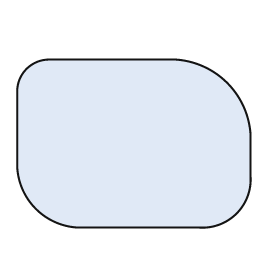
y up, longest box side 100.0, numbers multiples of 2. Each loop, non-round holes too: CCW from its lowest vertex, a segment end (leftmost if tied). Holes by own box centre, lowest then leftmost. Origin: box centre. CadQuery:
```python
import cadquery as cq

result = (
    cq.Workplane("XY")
    .moveTo(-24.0, -36.0)
    .lineTo(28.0, -36.0)
    .threePointArc((44.0, -30.0), (50.0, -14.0))
    .lineTo(50.0, 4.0)
    .threePointArc((40.0, 26.0), (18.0, 36.0))
    .lineTo(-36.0, 36.0)
    .threePointArc((-46.0, 32.0), (-50.0, 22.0))
    .lineTo(-50.0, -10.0)
    .threePointArc((-42.0, -28.0), (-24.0, -36.0))
    .close()
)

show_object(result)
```